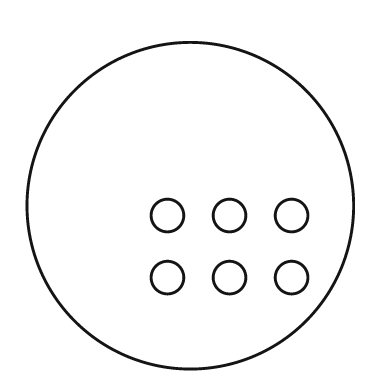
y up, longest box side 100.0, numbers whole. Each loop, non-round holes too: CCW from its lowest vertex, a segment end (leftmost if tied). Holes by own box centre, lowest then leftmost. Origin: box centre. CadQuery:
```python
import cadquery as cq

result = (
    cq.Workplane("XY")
    .moveTo(0.0, 0.0)
    .circle(50.0)
    .moveTo(-7.0, -22.0)
    .circle(5.0)
    .moveTo(12.0, -22.0)
    .circle(5.0)
    .moveTo(31.0, -22.0)
    .circle(5.0)
    .moveTo(-7.0, -3.0)
    .circle(5.0)
    .moveTo(12.0, -3.0)
    .circle(5.0)
    .moveTo(31.0, -3.0)
    .circle(5.0)
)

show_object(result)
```